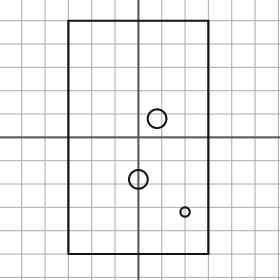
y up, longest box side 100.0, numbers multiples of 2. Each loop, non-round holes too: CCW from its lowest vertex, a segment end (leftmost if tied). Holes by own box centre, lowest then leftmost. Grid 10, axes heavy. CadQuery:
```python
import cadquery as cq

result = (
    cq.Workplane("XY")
    .moveTo(-30.0, -50.0)
    .lineTo(30.0, -50.0)
    .lineTo(30.0, 50.0)
    .lineTo(-30.0, 50.0)
    .close()
    .moveTo(20.0, -32.0)
    .circle(2.0)
    .moveTo(0.0, -18.0)
    .circle(4.0)
    .moveTo(8.0, 8.0)
    .circle(4.0)
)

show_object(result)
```